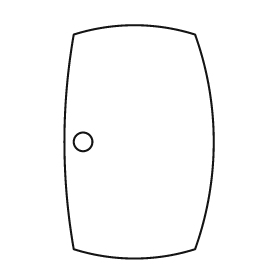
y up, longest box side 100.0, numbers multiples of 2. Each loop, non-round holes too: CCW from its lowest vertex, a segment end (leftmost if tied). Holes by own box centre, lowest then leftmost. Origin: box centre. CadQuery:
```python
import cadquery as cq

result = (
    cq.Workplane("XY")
    .moveTo(-28.0, -46.0)
    .threePointArc((-2.0, -50.0), (24.0, -46.0))
    .threePointArc((32.0, 0.0), (24.0, 46.0))
    .threePointArc((-2.0, 50.0), (-28.0, 46.0))
    .threePointArc((-32.0, 0.0), (-28.0, -46.0))
    .close()
    .moveTo(-24.0, 0.0)
    .circle(4.0)
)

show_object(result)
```